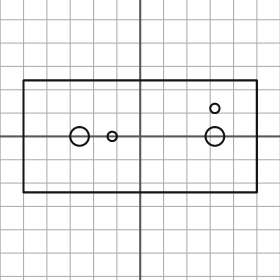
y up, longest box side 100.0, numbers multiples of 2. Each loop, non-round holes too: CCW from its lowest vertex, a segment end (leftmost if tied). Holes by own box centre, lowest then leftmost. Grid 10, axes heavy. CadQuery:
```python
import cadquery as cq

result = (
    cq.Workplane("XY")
    .moveTo(-50.0, -24.0)
    .lineTo(50.0, -24.0)
    .lineTo(50.0, 24.0)
    .lineTo(-50.0, 24.0)
    .close()
    .moveTo(-26.0, 0.0)
    .circle(4.0)
    .moveTo(-12.0, 0.0)
    .circle(2.0)
    .moveTo(32.0, 0.0)
    .circle(4.0)
    .moveTo(32.0, 12.0)
    .circle(2.0)
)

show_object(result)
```